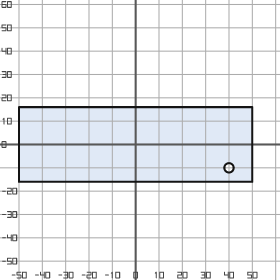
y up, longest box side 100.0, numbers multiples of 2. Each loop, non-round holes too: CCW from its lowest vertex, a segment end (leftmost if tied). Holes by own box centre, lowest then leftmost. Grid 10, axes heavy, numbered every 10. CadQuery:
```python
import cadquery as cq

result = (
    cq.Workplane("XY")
    .moveTo(-50.0, -16.0)
    .lineTo(50.0, -16.0)
    .lineTo(50.0, 16.0)
    .lineTo(-50.0, 16.0)
    .close()
    .moveTo(40.0, -10.0)
    .circle(2.0)
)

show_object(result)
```